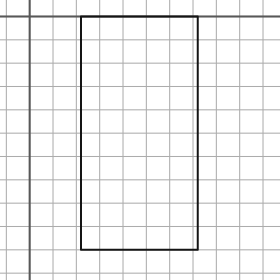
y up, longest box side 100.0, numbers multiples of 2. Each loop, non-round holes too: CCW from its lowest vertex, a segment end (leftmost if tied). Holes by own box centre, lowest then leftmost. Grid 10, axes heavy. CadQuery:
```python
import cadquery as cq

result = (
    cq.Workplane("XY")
    .moveTo(22.0, -100.0)
    .lineTo(72.0, -100.0)
    .lineTo(72.0, 0.0)
    .lineTo(22.0, 0.0)
    .close()
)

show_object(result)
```